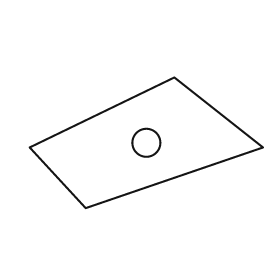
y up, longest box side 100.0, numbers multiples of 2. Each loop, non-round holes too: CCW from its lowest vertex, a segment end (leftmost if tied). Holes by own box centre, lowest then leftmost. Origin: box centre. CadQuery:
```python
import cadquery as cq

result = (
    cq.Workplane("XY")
    .moveTo(-26.0, -28.0)
    .lineTo(50.0, -2.0)
    .lineTo(12.0, 28.0)
    .lineTo(-50.0, -2.0)
    .close()
    .moveTo(0.0, 0.0)
    .circle(6.0)
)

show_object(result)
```